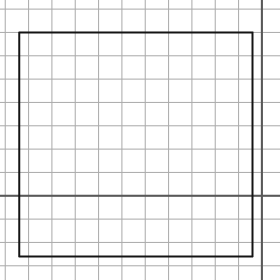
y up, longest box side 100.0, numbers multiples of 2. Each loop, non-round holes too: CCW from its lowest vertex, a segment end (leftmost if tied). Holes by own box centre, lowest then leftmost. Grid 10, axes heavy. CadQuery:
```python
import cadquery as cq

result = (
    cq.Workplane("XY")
    .moveTo(-104.0, -26.0)
    .lineTo(-4.0, -26.0)
    .lineTo(-4.0, 70.0)
    .lineTo(-104.0, 70.0)
    .close()
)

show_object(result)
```